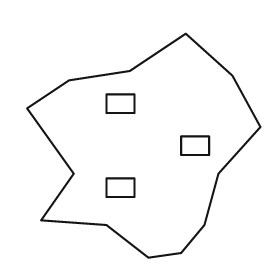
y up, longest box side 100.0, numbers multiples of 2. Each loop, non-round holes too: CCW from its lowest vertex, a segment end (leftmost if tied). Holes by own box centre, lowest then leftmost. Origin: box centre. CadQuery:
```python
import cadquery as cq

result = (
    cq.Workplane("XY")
    .moveTo(2.0, -48.0)
    .lineTo(16.0, -46.0)
    .lineTo(26.0, -34.0)
    .lineTo(32.0, -12.0)
    .lineTo(50.0, 8.0)
    .lineTo(38.0, 30.0)
    .lineTo(18.0, 48.0)
    .lineTo(-6.0, 32.0)
    .lineTo(-32.0, 28.0)
    .lineTo(-50.0, 16.0)
    .lineTo(-30.0, -12.0)
    .lineTo(-44.0, -32.0)
    .lineTo(-16.0, -34.0)
    .close()
    .moveTo(-16.0, -22.0)
    .lineTo(-4.0, -22.0)
    .lineTo(-4.0, -14.0)
    .lineTo(-16.0, -14.0)
    .close()
    .moveTo(16.0, -4.0)
    .lineTo(28.0, -4.0)
    .lineTo(28.0, 4.0)
    .lineTo(16.0, 4.0)
    .close()
    .moveTo(-16.0, 14.0)
    .lineTo(-4.0, 14.0)
    .lineTo(-4.0, 22.0)
    .lineTo(-16.0, 22.0)
    .close()
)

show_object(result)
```